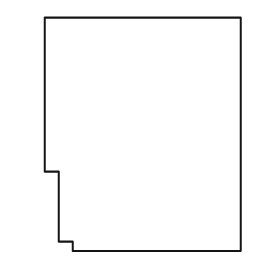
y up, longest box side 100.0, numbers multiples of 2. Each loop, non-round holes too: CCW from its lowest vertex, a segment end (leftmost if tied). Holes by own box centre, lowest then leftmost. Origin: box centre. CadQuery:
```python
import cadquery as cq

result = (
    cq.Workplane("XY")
    .moveTo(-30.0, -50.0)
    .lineTo(42.0, -50.0)
    .lineTo(42.0, 50.0)
    .lineTo(-42.0, 50.0)
    .lineTo(-42.0, -16.0)
    .lineTo(-36.0, -16.0)
    .lineTo(-36.0, -46.0)
    .lineTo(-30.0, -46.0)
    .close()
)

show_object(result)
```